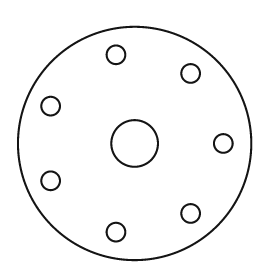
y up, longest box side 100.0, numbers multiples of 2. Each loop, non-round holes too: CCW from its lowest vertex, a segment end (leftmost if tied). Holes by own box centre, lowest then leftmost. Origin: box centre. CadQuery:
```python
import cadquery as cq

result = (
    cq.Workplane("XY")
    .moveTo(0.0, 0.0)
    .circle(50.0)
    .moveTo(-8.0, -38.0)
    .circle(4.0)
    .moveTo(24.0, -30.0)
    .circle(4.0)
    .moveTo(-36.0, -16.0)
    .circle(4.0)
    .moveTo(0.0, 0.0)
    .circle(10.0)
    .moveTo(38.0, 0.0)
    .circle(4.0)
    .moveTo(-36.0, 16.0)
    .circle(4.0)
    .moveTo(24.0, 30.0)
    .circle(4.0)
    .moveTo(-8.0, 38.0)
    .circle(4.0)
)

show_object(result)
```